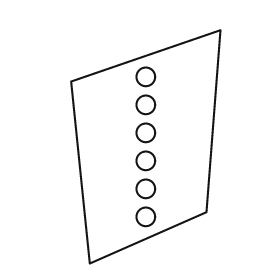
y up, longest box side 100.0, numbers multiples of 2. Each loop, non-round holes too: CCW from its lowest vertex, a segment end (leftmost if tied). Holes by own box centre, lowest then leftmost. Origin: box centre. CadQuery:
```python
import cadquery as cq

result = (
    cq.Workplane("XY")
    .moveTo(-24.0, -50.0)
    .lineTo(26.0, -28.0)
    .lineTo(32.0, 50.0)
    .lineTo(-32.0, 28.0)
    .close()
    .moveTo(0.0, -30.0)
    .circle(4.0)
    .moveTo(0.0, -18.0)
    .circle(4.0)
    .moveTo(0.0, -6.0)
    .circle(4.0)
    .moveTo(0.0, 6.0)
    .circle(4.0)
    .moveTo(0.0, 18.0)
    .circle(4.0)
    .moveTo(0.0, 30.0)
    .circle(4.0)
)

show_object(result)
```